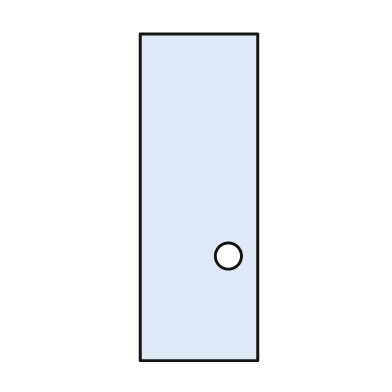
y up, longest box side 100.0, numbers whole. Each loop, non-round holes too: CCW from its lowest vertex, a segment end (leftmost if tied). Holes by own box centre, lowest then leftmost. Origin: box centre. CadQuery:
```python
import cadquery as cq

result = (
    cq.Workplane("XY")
    .moveTo(-18.0, -50.0)
    .lineTo(18.0, -50.0)
    .lineTo(18.0, 50.0)
    .lineTo(-18.0, 50.0)
    .close()
    .moveTo(9.0, -18.0)
    .circle(4.0)
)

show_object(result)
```